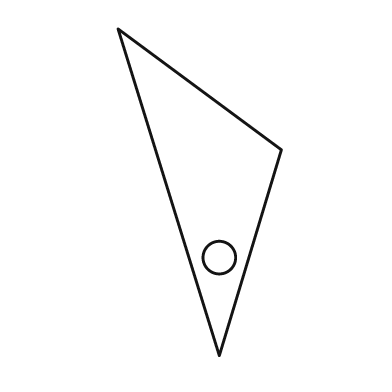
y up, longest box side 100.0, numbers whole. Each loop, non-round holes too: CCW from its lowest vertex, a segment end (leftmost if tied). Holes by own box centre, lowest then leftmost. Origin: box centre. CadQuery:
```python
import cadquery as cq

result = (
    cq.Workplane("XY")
    .moveTo(6.0, -50.0)
    .lineTo(25.0, 13.0)
    .lineTo(-25.0, 50.0)
    .close()
    .moveTo(6.0, -20.0)
    .circle(5.0)
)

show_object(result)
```